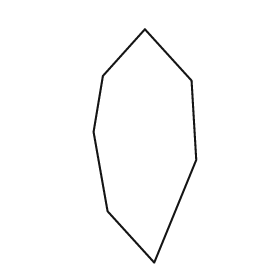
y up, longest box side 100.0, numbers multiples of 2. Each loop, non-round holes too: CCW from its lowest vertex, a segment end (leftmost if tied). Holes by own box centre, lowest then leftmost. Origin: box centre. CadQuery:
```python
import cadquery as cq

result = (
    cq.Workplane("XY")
    .moveTo(4.0, -50.0)
    .lineTo(22.0, -6.0)
    .lineTo(20.0, 28.0)
    .lineTo(0.0, 50.0)
    .lineTo(-18.0, 30.0)
    .lineTo(-22.0, 6.0)
    .lineTo(-16.0, -28.0)
    .close()
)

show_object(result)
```